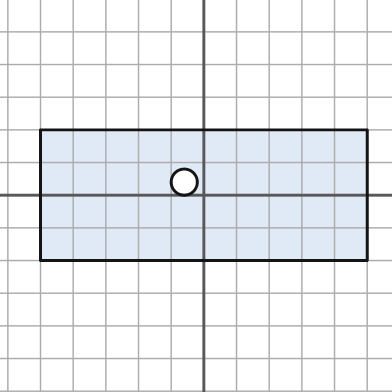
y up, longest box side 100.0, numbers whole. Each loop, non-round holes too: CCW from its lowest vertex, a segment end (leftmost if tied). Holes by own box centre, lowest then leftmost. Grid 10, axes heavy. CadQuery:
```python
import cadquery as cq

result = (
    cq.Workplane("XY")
    .moveTo(-50.0, -20.0)
    .lineTo(50.0, -20.0)
    .lineTo(50.0, 20.0)
    .lineTo(-50.0, 20.0)
    .close()
    .moveTo(-6.0, 4.0)
    .circle(4.0)
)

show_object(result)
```